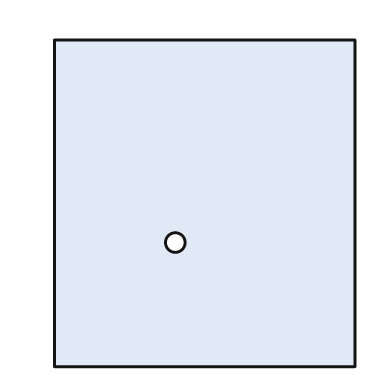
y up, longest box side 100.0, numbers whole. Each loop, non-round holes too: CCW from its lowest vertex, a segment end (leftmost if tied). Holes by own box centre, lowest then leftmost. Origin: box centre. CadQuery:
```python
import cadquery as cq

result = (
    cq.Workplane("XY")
    .moveTo(-46.0, -50.0)
    .lineTo(46.0, -50.0)
    .lineTo(46.0, 50.0)
    .lineTo(-46.0, 50.0)
    .close()
    .moveTo(-9.0, -12.0)
    .circle(3.0)
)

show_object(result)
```